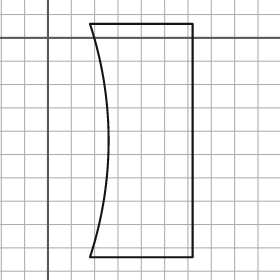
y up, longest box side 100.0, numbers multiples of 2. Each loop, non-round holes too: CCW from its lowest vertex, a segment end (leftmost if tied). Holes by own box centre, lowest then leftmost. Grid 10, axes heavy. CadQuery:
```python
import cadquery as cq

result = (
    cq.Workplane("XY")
    .moveTo(18.0, -94.0)
    .lineTo(62.0, -94.0)
    .lineTo(62.0, 6.0)
    .lineTo(18.0, 6.0)
    .threePointArc((26.0, -44.0), (18.0, -94.0))
    .close()
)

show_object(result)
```